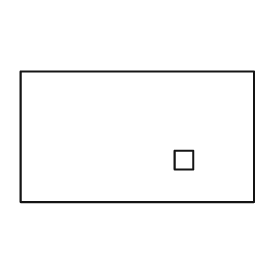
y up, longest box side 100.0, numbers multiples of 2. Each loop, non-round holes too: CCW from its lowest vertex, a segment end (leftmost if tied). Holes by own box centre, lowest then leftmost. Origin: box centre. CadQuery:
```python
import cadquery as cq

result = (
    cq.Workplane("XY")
    .moveTo(-50.0, -28.0)
    .lineTo(50.0, -28.0)
    .lineTo(50.0, 28.0)
    .lineTo(-50.0, 28.0)
    .close()
    .moveTo(16.0, -14.0)
    .lineTo(24.0, -14.0)
    .lineTo(24.0, -6.0)
    .lineTo(16.0, -6.0)
    .close()
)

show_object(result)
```